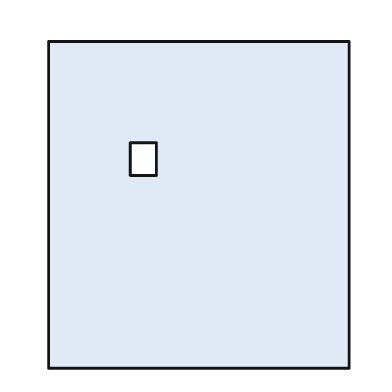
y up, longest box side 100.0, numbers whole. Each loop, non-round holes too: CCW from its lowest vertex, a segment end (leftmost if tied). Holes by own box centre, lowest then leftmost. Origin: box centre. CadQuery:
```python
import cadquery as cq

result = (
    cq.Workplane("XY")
    .moveTo(-46.0, -50.0)
    .lineTo(46.0, -50.0)
    .lineTo(46.0, 50.0)
    .lineTo(-46.0, 50.0)
    .close()
    .moveTo(-21.0, 9.0)
    .lineTo(-13.0, 9.0)
    .lineTo(-13.0, 19.0)
    .lineTo(-21.0, 19.0)
    .close()
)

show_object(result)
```